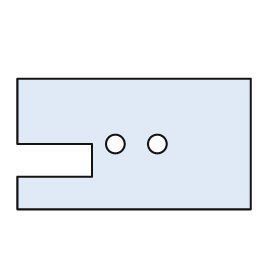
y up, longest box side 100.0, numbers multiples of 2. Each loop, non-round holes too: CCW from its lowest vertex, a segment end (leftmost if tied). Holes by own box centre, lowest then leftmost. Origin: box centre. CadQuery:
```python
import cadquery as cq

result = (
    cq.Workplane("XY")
    .moveTo(-50.0, -28.0)
    .lineTo(50.0, -28.0)
    .lineTo(50.0, 28.0)
    .lineTo(-50.0, 28.0)
    .lineTo(-50.0, 0.0)
    .lineTo(-18.0, 0.0)
    .lineTo(-18.0, -14.0)
    .lineTo(-50.0, -14.0)
    .close()
    .moveTo(-8.0, 0.0)
    .circle(4.0)
    .moveTo(10.0, 0.0)
    .circle(4.0)
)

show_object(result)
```